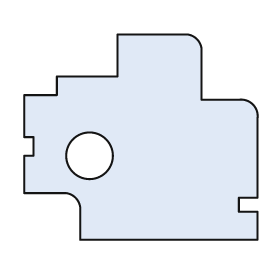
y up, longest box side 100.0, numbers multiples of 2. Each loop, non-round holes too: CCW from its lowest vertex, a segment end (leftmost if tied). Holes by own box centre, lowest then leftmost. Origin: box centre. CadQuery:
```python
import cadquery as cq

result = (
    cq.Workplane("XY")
    .moveTo(-26.0, -44.0)
    .lineTo(50.0, -44.0)
    .lineTo(50.0, -32.0)
    .lineTo(42.0, -32.0)
    .lineTo(42.0, -26.0)
    .lineTo(50.0, -26.0)
    .lineTo(50.0, 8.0)
    .threePointArc((48.0, 14.0), (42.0, 16.0))
    .lineTo(26.0, 16.0)
    .lineTo(26.0, 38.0)
    .threePointArc((24.0, 42.0), (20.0, 44.0))
    .lineTo(-10.0, 44.0)
    .lineTo(-10.0, 26.0)
    .lineTo(-36.0, 26.0)
    .lineTo(-36.0, 18.0)
    .lineTo(-50.0, 18.0)
    .lineTo(-50.0, 0.0)
    .lineTo(-46.0, 0.0)
    .lineTo(-46.0, -8.0)
    .lineTo(-50.0, -8.0)
    .lineTo(-50.0, -24.0)
    .lineTo(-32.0, -24.0)
    .threePointArc((-28.0, -26.0), (-26.0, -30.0))
    .close()
    .moveTo(-22.0, -8.0)
    .circle(10.0)
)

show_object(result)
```